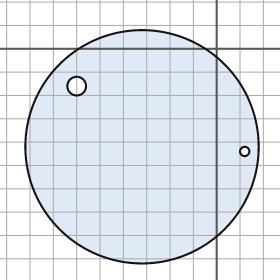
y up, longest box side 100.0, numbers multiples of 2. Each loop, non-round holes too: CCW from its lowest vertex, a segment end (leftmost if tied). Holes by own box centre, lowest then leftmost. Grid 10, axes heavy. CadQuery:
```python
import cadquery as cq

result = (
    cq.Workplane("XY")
    .moveTo(-32.0, -42.0)
    .circle(50.0)
    .moveTo(12.0, -44.0)
    .circle(2.0)
    .moveTo(-60.0, -16.0)
    .circle(4.0)
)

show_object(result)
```